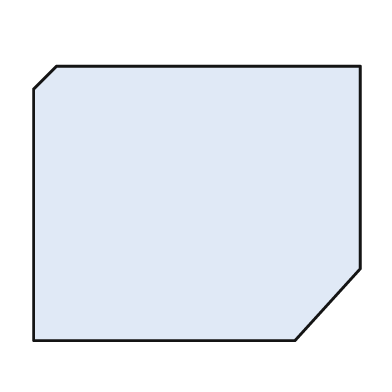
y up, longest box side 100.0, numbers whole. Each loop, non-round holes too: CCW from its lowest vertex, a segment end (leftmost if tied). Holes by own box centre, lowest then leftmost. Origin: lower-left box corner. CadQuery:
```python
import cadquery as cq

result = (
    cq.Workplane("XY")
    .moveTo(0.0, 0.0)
    .lineTo(80.0, 0.0)
    .lineTo(100.0, 22.0)
    .lineTo(100.0, 84.0)
    .lineTo(7.0, 84.0)
    .lineTo(0.0, 77.0)
    .close()
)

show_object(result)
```